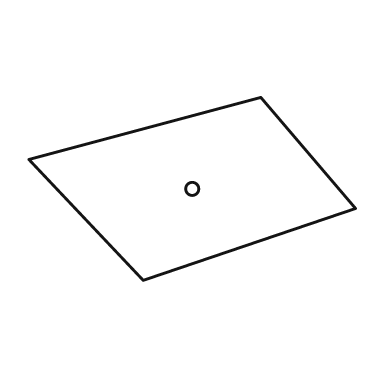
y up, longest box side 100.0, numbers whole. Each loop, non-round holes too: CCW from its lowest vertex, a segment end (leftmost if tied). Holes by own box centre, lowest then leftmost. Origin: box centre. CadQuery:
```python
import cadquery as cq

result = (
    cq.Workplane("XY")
    .moveTo(-15.0, -28.0)
    .lineTo(50.0, -6.0)
    .lineTo(21.0, 28.0)
    .lineTo(-50.0, 9.0)
    .close()
    .moveTo(0.0, 0.0)
    .circle(2.0)
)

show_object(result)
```